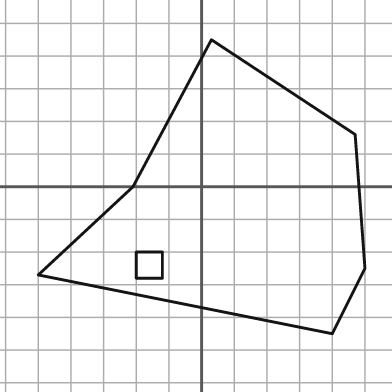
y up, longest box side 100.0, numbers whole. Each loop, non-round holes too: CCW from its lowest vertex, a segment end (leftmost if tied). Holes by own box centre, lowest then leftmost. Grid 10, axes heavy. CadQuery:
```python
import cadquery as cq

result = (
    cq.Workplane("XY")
    .moveTo(40.0, -45.0)
    .lineTo(50.0, -25.0)
    .lineTo(47.0, 16.0)
    .lineTo(3.0, 45.0)
    .lineTo(-21.0, 0.0)
    .lineTo(-50.0, -27.0)
    .close()
    .moveTo(-20.0, -28.0)
    .lineTo(-12.0, -28.0)
    .lineTo(-12.0, -20.0)
    .lineTo(-20.0, -20.0)
    .close()
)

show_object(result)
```